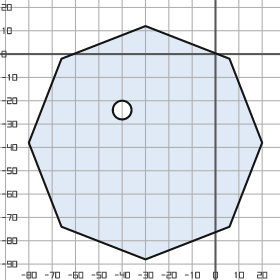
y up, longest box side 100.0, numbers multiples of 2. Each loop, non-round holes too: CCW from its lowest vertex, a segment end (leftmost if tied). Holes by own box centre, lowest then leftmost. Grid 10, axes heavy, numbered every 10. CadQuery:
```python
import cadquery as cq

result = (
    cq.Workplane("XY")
    .moveTo(-30.0, -88.0)
    .lineTo(6.0, -74.0)
    .lineTo(20.0, -38.0)
    .lineTo(6.0, -2.0)
    .lineTo(-30.0, 12.0)
    .lineTo(-66.0, -2.0)
    .lineTo(-80.0, -38.0)
    .lineTo(-66.0, -74.0)
    .close()
    .moveTo(-40.0, -24.0)
    .circle(4.0)
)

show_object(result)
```